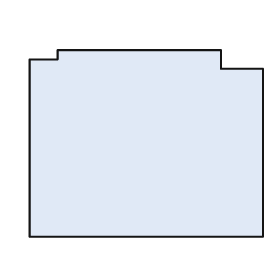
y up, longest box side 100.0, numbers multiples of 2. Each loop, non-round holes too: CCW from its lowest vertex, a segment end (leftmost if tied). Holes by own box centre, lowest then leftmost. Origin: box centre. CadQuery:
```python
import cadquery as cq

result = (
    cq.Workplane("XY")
    .moveTo(-50.0, -40.0)
    .lineTo(50.0, -40.0)
    .lineTo(50.0, 32.0)
    .lineTo(32.0, 32.0)
    .lineTo(32.0, 40.0)
    .lineTo(-38.0, 40.0)
    .lineTo(-38.0, 36.0)
    .lineTo(-50.0, 36.0)
    .close()
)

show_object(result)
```